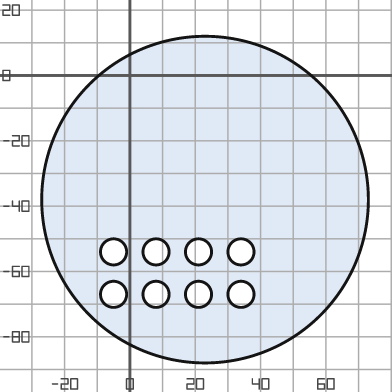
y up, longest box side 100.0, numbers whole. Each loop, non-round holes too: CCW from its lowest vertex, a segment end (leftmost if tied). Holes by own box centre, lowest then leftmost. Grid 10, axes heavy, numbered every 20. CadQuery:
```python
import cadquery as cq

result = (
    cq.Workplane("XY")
    .moveTo(23.0, -38.0)
    .circle(50.0)
    .moveTo(-5.0, -67.0)
    .circle(4.0)
    .moveTo(8.0, -67.0)
    .circle(4.0)
    .moveTo(21.0, -67.0)
    .circle(4.0)
    .moveTo(34.0, -67.0)
    .circle(4.0)
    .moveTo(-5.0, -54.0)
    .circle(4.0)
    .moveTo(8.0, -54.0)
    .circle(4.0)
    .moveTo(21.0, -54.0)
    .circle(4.0)
    .moveTo(34.0, -54.0)
    .circle(4.0)
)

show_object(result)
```